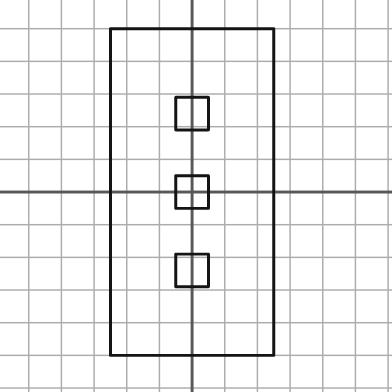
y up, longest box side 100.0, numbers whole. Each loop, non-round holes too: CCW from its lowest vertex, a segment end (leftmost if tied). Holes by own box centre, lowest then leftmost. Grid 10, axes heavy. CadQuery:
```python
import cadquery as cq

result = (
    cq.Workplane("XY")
    .moveTo(-25.0, -50.0)
    .lineTo(25.0, -50.0)
    .lineTo(25.0, 50.0)
    .lineTo(-25.0, 50.0)
    .close()
    .moveTo(-5.0, -29.0)
    .lineTo(5.0, -29.0)
    .lineTo(5.0, -19.0)
    .lineTo(-5.0, -19.0)
    .close()
    .moveTo(-5.0, -5.0)
    .lineTo(5.0, -5.0)
    .lineTo(5.0, 5.0)
    .lineTo(-5.0, 5.0)
    .close()
    .moveTo(-5.0, 19.0)
    .lineTo(5.0, 19.0)
    .lineTo(5.0, 29.0)
    .lineTo(-5.0, 29.0)
    .close()
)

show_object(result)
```